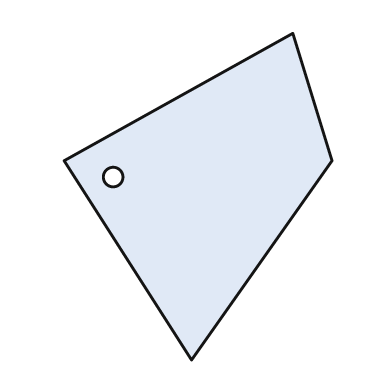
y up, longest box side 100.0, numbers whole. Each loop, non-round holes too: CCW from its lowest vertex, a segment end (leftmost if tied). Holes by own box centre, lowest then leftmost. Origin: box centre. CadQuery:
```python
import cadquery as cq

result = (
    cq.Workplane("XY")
    .moveTo(-2.0, -50.0)
    .lineTo(41.0, 11.0)
    .lineTo(29.0, 50.0)
    .lineTo(-41.0, 11.0)
    .close()
    .moveTo(-26.0, 6.0)
    .circle(3.0)
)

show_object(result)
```